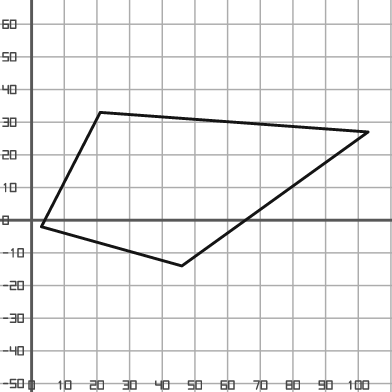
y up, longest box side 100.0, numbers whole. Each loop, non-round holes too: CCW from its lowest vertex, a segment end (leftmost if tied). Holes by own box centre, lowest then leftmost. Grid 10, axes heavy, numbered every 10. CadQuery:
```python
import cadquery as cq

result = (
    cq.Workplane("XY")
    .moveTo(46.0, -14.0)
    .lineTo(103.0, 27.0)
    .lineTo(21.0, 33.0)
    .lineTo(3.0, -2.0)
    .close()
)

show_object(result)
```